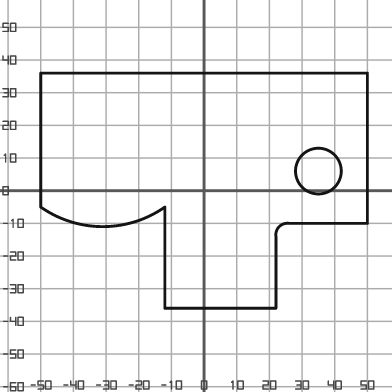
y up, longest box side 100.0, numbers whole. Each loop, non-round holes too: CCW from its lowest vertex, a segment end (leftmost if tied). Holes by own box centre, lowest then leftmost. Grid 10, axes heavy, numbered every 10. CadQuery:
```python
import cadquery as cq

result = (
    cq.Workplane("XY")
    .moveTo(-12.0, -36.0)
    .lineTo(22.0, -36.0)
    .lineTo(22.0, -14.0)
    .threePointArc((23.0, -11.0), (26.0, -10.0))
    .lineTo(50.0, -10.0)
    .lineTo(50.0, 36.0)
    .lineTo(-50.0, 36.0)
    .lineTo(-50.0, -5.0)
    .threePointArc((-31.0, -11.0), (-12.0, -5.0))
    .close()
    .moveTo(35.0, 6.0)
    .circle(7.0)
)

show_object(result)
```